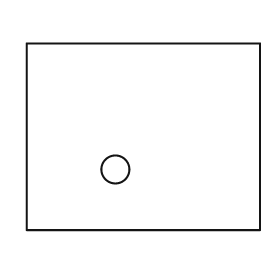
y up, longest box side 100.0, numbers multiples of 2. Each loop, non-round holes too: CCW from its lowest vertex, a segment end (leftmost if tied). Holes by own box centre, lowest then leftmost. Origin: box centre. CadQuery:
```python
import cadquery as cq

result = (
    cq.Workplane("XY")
    .moveTo(-50.0, -40.0)
    .lineTo(50.0, -40.0)
    .lineTo(50.0, 40.0)
    .lineTo(-50.0, 40.0)
    .close()
    .moveTo(-12.0, -14.0)
    .circle(6.0)
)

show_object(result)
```